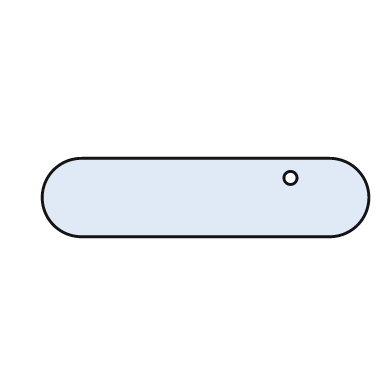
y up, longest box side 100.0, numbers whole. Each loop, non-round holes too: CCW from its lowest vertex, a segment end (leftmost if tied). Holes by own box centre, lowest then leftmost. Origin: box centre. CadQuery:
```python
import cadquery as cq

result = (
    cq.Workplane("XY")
    .moveTo(-38.0, -12.0)
    .lineTo(38.0, -12.0)
    .threePointArc((50.0, 0.0), (38.0, 12.0))
    .lineTo(-38.0, 12.0)
    .threePointArc((-50.0, 0.0), (-38.0, -12.0))
    .close()
    .moveTo(26.0, 6.0)
    .circle(2.0)
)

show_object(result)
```